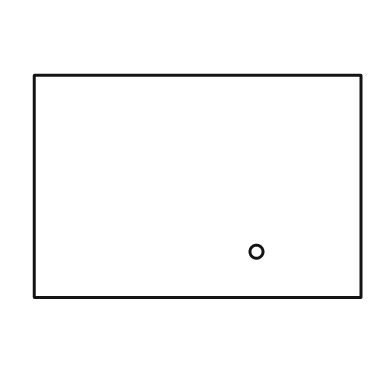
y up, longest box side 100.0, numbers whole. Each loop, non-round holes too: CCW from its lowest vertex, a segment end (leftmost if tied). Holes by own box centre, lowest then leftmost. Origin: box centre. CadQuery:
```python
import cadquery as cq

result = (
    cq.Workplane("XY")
    .moveTo(-50.0, -34.0)
    .lineTo(50.0, -34.0)
    .lineTo(50.0, 34.0)
    .lineTo(-50.0, 34.0)
    .close()
    .moveTo(18.0, -20.0)
    .circle(2.0)
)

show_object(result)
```